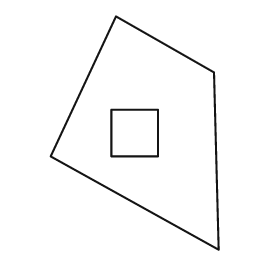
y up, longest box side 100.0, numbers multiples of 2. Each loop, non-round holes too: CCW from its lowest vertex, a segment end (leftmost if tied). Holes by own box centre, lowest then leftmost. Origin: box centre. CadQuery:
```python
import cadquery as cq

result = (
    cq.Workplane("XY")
    .moveTo(36.0, -50.0)
    .lineTo(34.0, 26.0)
    .lineTo(-8.0, 50.0)
    .lineTo(-36.0, -10.0)
    .close()
    .moveTo(-10.0, -10.0)
    .lineTo(10.0, -10.0)
    .lineTo(10.0, 10.0)
    .lineTo(-10.0, 10.0)
    .close()
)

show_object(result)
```